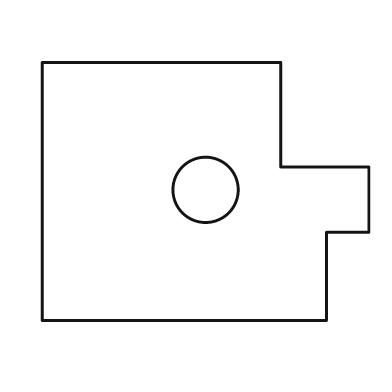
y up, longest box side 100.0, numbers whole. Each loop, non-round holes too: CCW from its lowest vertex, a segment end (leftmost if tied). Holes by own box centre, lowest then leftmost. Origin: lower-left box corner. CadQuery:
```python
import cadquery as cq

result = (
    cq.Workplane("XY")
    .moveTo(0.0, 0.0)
    .lineTo(87.0, 0.0)
    .lineTo(87.0, 27.0)
    .lineTo(100.0, 27.0)
    .lineTo(100.0, 47.0)
    .lineTo(73.0, 47.0)
    .lineTo(73.0, 79.0)
    .lineTo(0.0, 79.0)
    .close()
    .moveTo(50.0, 40.0)
    .circle(10.0)
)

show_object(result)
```